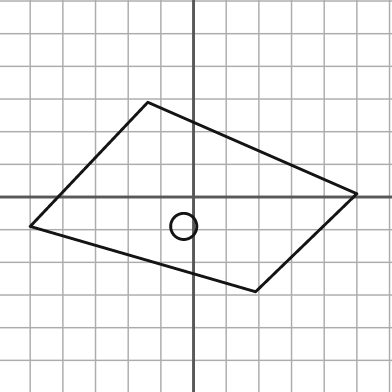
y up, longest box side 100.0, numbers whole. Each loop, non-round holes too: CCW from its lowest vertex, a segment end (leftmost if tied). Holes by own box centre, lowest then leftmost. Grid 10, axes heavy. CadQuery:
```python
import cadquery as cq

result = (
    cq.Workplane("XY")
    .moveTo(19.0, -29.0)
    .lineTo(50.0, 1.0)
    .lineTo(-14.0, 29.0)
    .lineTo(-50.0, -9.0)
    .close()
    .moveTo(-3.0, -9.0)
    .circle(4.0)
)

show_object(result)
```